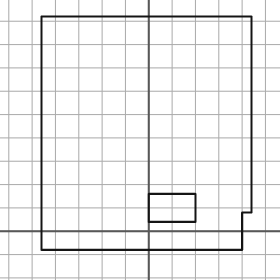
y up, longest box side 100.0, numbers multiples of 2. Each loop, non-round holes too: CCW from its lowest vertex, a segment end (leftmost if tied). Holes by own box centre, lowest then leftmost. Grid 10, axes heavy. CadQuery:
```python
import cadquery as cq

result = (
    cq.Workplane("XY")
    .moveTo(-46.0, -8.0)
    .lineTo(40.0, -8.0)
    .lineTo(40.0, 8.0)
    .lineTo(44.0, 8.0)
    .lineTo(44.0, 92.0)
    .lineTo(-46.0, 92.0)
    .close()
    .moveTo(0.0, 4.0)
    .lineTo(20.0, 4.0)
    .lineTo(20.0, 16.0)
    .lineTo(0.0, 16.0)
    .close()
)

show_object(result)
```